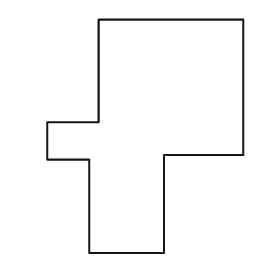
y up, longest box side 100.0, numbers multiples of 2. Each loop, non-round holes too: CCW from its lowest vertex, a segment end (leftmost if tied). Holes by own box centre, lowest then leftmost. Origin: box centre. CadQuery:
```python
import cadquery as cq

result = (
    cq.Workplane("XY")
    .moveTo(-24.0, -50.0)
    .lineTo(8.0, -50.0)
    .lineTo(8.0, -8.0)
    .lineTo(42.0, -8.0)
    .lineTo(42.0, 50.0)
    .lineTo(-20.0, 50.0)
    .lineTo(-20.0, 6.0)
    .lineTo(-42.0, 6.0)
    .lineTo(-42.0, -10.0)
    .lineTo(-24.0, -10.0)
    .close()
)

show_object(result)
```